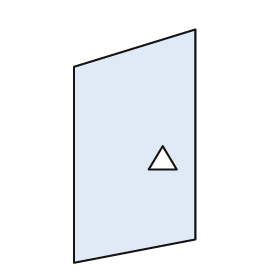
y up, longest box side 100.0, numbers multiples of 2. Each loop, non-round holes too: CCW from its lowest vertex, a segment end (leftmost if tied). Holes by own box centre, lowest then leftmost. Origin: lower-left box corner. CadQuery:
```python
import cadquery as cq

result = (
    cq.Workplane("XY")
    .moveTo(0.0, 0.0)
    .lineTo(52.0, 10.0)
    .lineTo(52.0, 100.0)
    .lineTo(0.0, 84.0)
    .close()
    .moveTo(32.0, 40.0)
    .lineTo(44.0, 40.0)
    .lineTo(38.0, 50.0)
    .close()
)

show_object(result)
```